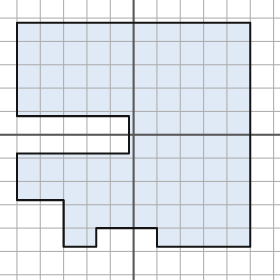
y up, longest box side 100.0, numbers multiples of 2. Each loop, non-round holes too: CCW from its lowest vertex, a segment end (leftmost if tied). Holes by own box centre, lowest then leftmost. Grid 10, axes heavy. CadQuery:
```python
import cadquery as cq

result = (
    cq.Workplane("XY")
    .moveTo(-30.0, -48.0)
    .lineTo(-16.0, -48.0)
    .lineTo(-16.0, -40.0)
    .lineTo(10.0, -40.0)
    .lineTo(10.0, -48.0)
    .lineTo(50.0, -48.0)
    .lineTo(50.0, 48.0)
    .lineTo(-50.0, 48.0)
    .lineTo(-50.0, 8.0)
    .lineTo(-2.0, 8.0)
    .lineTo(-2.0, -8.0)
    .lineTo(-50.0, -8.0)
    .lineTo(-50.0, -28.0)
    .lineTo(-30.0, -28.0)
    .close()
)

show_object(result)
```